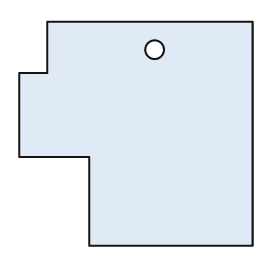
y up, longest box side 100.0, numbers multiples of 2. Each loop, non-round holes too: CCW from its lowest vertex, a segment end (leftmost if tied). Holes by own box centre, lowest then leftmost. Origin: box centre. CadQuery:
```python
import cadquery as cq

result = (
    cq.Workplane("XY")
    .moveTo(-20.0, -48.0)
    .lineTo(50.0, -48.0)
    .lineTo(50.0, 48.0)
    .lineTo(-38.0, 48.0)
    .lineTo(-38.0, 26.0)
    .lineTo(-50.0, 26.0)
    .lineTo(-50.0, -10.0)
    .lineTo(-20.0, -10.0)
    .close()
    .moveTo(8.0, 36.0)
    .circle(4.0)
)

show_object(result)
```